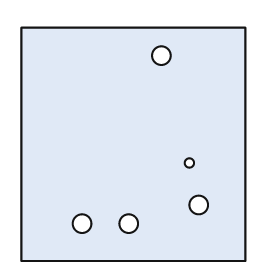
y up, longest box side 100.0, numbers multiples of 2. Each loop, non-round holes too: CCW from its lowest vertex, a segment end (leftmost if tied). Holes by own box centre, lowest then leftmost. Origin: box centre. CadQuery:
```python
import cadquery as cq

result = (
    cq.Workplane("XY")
    .moveTo(-48.0, -50.0)
    .lineTo(48.0, -50.0)
    .lineTo(48.0, 50.0)
    .lineTo(-48.0, 50.0)
    .close()
    .moveTo(-22.0, -34.0)
    .circle(4.0)
    .moveTo(-2.0, -34.0)
    .circle(4.0)
    .moveTo(28.0, -26.0)
    .circle(4.0)
    .moveTo(24.0, -8.0)
    .circle(2.0)
    .moveTo(12.0, 38.0)
    .circle(4.0)
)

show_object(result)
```